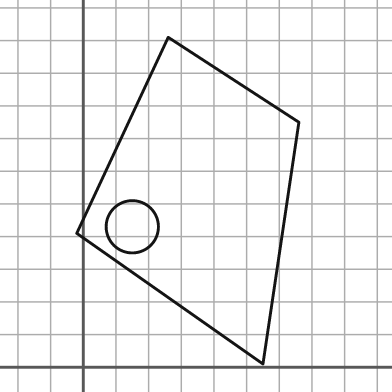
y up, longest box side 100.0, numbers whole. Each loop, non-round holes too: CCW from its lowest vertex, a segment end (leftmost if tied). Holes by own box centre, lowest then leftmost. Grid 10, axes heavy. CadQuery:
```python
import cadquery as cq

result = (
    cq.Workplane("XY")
    .moveTo(55.0, 1.0)
    .lineTo(66.0, 75.0)
    .lineTo(26.0, 101.0)
    .lineTo(-2.0, 41.0)
    .close()
    .moveTo(15.0, 43.0)
    .circle(8.0)
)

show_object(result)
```